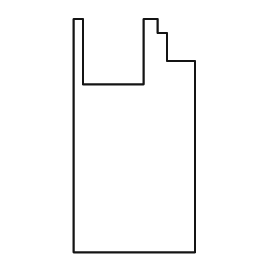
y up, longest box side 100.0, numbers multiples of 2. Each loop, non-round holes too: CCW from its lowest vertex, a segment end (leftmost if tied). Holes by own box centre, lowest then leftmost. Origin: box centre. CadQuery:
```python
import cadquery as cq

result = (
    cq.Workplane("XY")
    .moveTo(-26.0, -50.0)
    .lineTo(26.0, -50.0)
    .lineTo(26.0, 32.0)
    .lineTo(14.0, 32.0)
    .lineTo(14.0, 44.0)
    .lineTo(10.0, 44.0)
    .lineTo(10.0, 50.0)
    .lineTo(4.0, 50.0)
    .lineTo(4.0, 22.0)
    .lineTo(-22.0, 22.0)
    .lineTo(-22.0, 50.0)
    .lineTo(-26.0, 50.0)
    .close()
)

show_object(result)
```